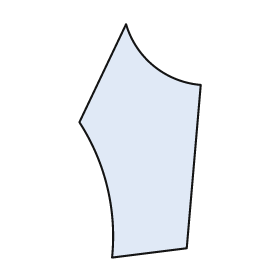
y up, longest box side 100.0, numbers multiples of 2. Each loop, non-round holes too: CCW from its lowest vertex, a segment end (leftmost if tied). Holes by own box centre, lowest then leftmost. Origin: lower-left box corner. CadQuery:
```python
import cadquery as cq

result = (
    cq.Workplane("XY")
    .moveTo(14.0, 0.0)
    .lineTo(46.0, 4.0)
    .lineTo(52.0, 74.0)
    .threePointArc((32.0, 82.0), (20.0, 100.0))
    .lineTo(0.0, 58.0)
    .threePointArc((12.0, 30.0), (14.0, 0.0))
    .close()
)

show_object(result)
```